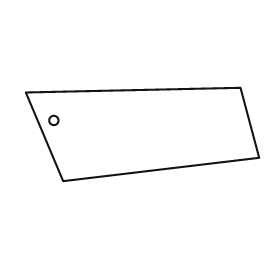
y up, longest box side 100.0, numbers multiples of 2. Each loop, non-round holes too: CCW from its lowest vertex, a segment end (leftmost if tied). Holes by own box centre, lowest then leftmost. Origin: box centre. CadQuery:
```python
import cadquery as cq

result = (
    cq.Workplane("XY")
    .moveTo(-34.0, -20.0)
    .lineTo(50.0, -10.0)
    .lineTo(42.0, 20.0)
    .lineTo(-50.0, 18.0)
    .close()
    .moveTo(-38.0, 6.0)
    .circle(2.0)
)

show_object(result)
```